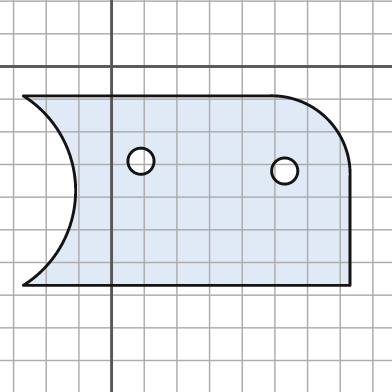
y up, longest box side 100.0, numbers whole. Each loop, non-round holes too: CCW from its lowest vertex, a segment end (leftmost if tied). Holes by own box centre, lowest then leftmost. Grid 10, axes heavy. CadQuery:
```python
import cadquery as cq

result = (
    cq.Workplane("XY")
    .moveTo(-27.0, -67.0)
    .lineTo(73.0, -67.0)
    .lineTo(73.0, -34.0)
    .threePointArc((66.0, -16.0), (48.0, -9.0))
    .lineTo(-27.0, -9.0)
    .threePointArc((-11.0, -38.0), (-27.0, -67.0))
    .close()
    .moveTo(53.0, -32.0)
    .circle(4.0)
    .moveTo(9.0, -29.0)
    .circle(4.0)
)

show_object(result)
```